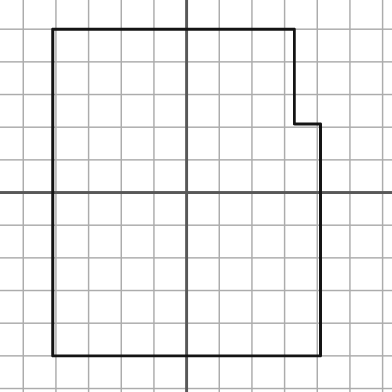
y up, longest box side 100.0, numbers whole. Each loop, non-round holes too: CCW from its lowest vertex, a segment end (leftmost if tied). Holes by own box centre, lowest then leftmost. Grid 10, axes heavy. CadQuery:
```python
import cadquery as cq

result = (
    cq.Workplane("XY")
    .moveTo(-41.0, -50.0)
    .lineTo(41.0, -50.0)
    .lineTo(41.0, 21.0)
    .lineTo(33.0, 21.0)
    .lineTo(33.0, 50.0)
    .lineTo(-41.0, 50.0)
    .close()
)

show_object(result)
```